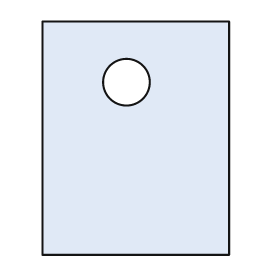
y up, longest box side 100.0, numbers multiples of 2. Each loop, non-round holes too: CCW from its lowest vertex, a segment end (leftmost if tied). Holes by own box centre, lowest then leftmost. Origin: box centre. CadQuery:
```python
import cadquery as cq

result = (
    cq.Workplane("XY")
    .moveTo(-40.0, -50.0)
    .lineTo(40.0, -50.0)
    .lineTo(40.0, 50.0)
    .lineTo(-40.0, 50.0)
    .close()
    .moveTo(-4.0, 24.0)
    .circle(10.0)
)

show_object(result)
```